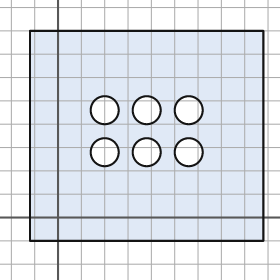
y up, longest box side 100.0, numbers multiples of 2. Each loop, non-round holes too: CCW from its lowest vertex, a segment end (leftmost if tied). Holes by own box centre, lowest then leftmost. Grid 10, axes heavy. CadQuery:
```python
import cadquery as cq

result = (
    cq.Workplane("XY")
    .moveTo(-12.0, -10.0)
    .lineTo(88.0, -10.0)
    .lineTo(88.0, 80.0)
    .lineTo(-12.0, 80.0)
    .close()
    .moveTo(20.0, 28.0)
    .circle(6.0)
    .moveTo(38.0, 28.0)
    .circle(6.0)
    .moveTo(56.0, 28.0)
    .circle(6.0)
    .moveTo(20.0, 46.0)
    .circle(6.0)
    .moveTo(38.0, 46.0)
    .circle(6.0)
    .moveTo(56.0, 46.0)
    .circle(6.0)
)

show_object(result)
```